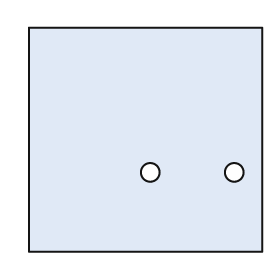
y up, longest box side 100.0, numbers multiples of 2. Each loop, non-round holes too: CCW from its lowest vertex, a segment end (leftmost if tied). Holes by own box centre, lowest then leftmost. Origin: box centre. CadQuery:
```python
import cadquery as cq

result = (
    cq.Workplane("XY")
    .moveTo(-50.0, -48.0)
    .lineTo(50.0, -48.0)
    .lineTo(50.0, 48.0)
    .lineTo(-50.0, 48.0)
    .close()
    .moveTo(2.0, -14.0)
    .circle(4.0)
    .moveTo(38.0, -14.0)
    .circle(4.0)
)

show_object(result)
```